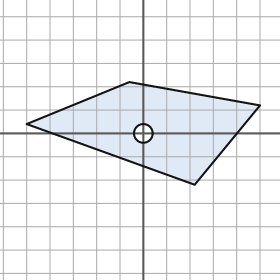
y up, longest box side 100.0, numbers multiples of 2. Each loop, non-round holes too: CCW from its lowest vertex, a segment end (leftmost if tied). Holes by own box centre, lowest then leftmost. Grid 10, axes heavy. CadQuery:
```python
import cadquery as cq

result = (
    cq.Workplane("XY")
    .moveTo(22.0, -22.0)
    .lineTo(50.0, 12.0)
    .lineTo(-6.0, 22.0)
    .lineTo(-50.0, 4.0)
    .close()
    .moveTo(0.0, 0.0)
    .circle(4.0)
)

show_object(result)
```